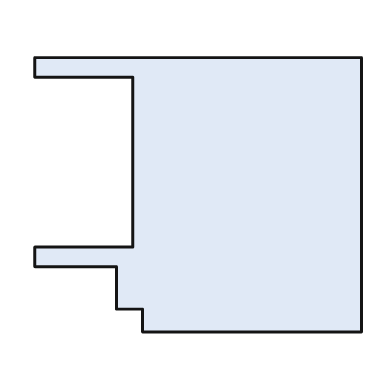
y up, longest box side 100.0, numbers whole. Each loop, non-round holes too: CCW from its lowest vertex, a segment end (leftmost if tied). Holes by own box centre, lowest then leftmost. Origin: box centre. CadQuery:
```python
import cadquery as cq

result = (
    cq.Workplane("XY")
    .moveTo(-17.0, -42.0)
    .lineTo(50.0, -42.0)
    .lineTo(50.0, 42.0)
    .lineTo(-50.0, 42.0)
    .lineTo(-50.0, 36.0)
    .lineTo(-20.0, 36.0)
    .lineTo(-20.0, -16.0)
    .lineTo(-50.0, -16.0)
    .lineTo(-50.0, -22.0)
    .lineTo(-25.0, -22.0)
    .lineTo(-25.0, -35.0)
    .lineTo(-17.0, -35.0)
    .close()
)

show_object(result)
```